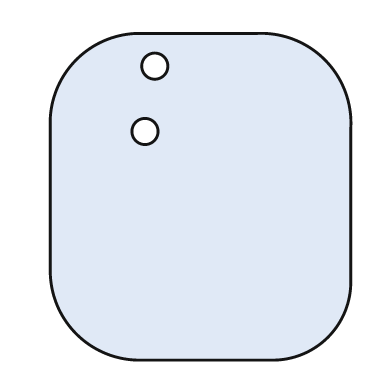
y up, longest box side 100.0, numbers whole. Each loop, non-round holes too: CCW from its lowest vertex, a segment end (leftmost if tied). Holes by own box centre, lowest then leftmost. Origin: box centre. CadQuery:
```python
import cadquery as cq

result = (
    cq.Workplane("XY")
    .moveTo(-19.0, -50.0)
    .lineTo(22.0, -50.0)
    .threePointArc((39.0, -43.0), (46.0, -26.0))
    .lineTo(46.0, 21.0)
    .threePointArc((38.0, 42.0), (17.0, 50.0))
    .lineTo(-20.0, 50.0)
    .threePointArc((-38.0, 42.0), (-46.0, 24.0))
    .lineTo(-46.0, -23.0)
    .threePointArc((-38.0, -42.0), (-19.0, -50.0))
    .close()
    .moveTo(-17.0, 20.0)
    .circle(4.0)
    .moveTo(-14.0, 40.0)
    .circle(4.0)
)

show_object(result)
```